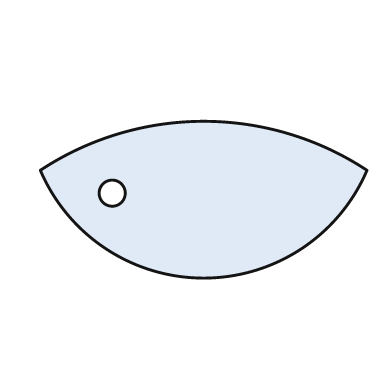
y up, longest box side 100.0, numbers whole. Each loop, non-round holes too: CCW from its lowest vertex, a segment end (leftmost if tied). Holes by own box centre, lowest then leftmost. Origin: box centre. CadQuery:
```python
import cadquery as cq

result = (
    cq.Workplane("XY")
    .moveTo(-50.0, 9.0)
    .threePointArc((0.0, -24.0), (50.0, 9.0))
    .threePointArc((0.0, 24.0), (-50.0, 9.0))
    .close()
    .moveTo(-28.0, 2.0)
    .circle(4.0)
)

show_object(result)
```